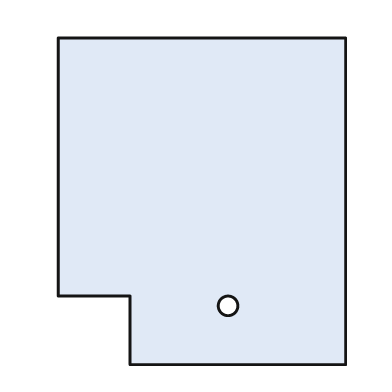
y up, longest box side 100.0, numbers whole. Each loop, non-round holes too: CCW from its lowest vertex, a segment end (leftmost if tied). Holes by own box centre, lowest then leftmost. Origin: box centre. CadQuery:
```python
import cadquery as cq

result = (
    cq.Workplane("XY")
    .moveTo(-22.0, -50.0)
    .lineTo(44.0, -50.0)
    .lineTo(44.0, 50.0)
    .lineTo(-44.0, 50.0)
    .lineTo(-44.0, -29.0)
    .lineTo(-22.0, -29.0)
    .close()
    .moveTo(8.0, -32.0)
    .circle(3.0)
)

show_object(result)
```